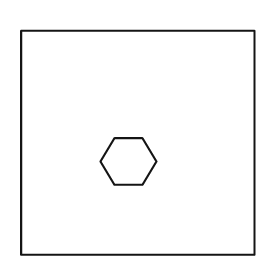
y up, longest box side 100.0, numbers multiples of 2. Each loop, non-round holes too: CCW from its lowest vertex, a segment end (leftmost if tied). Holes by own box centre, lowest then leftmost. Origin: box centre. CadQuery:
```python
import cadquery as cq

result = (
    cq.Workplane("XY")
    .moveTo(-50.0, -48.0)
    .lineTo(50.0, -48.0)
    .lineTo(50.0, 48.0)
    .lineTo(-50.0, 48.0)
    .close()
    .moveTo(-10.0, -18.0)
    .lineTo(2.0, -18.0)
    .lineTo(8.0, -8.0)
    .lineTo(2.0, 2.0)
    .lineTo(-10.0, 2.0)
    .lineTo(-16.0, -8.0)
    .close()
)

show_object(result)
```